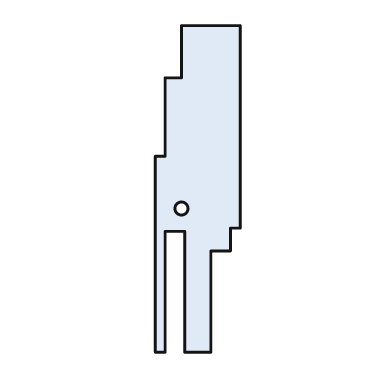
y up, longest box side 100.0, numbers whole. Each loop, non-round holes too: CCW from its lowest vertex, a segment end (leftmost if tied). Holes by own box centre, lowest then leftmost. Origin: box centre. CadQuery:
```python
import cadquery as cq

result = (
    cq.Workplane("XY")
    .moveTo(-13.0, -50.0)
    .lineTo(-10.0, -50.0)
    .lineTo(-10.0, -13.0)
    .lineTo(-4.0, -13.0)
    .lineTo(-4.0, -50.0)
    .lineTo(4.0, -50.0)
    .lineTo(4.0, -19.0)
    .lineTo(10.0, -19.0)
    .lineTo(10.0, -12.0)
    .lineTo(13.0, -12.0)
    .lineTo(13.0, 50.0)
    .lineTo(-5.0, 50.0)
    .lineTo(-5.0, 34.0)
    .lineTo(-10.0, 34.0)
    .lineTo(-10.0, 10.0)
    .lineTo(-13.0, 10.0)
    .close()
    .moveTo(-5.0, -6.0)
    .circle(2.0)
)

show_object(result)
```